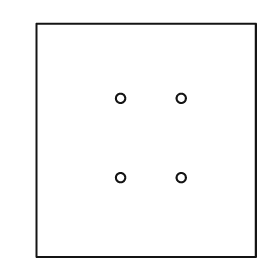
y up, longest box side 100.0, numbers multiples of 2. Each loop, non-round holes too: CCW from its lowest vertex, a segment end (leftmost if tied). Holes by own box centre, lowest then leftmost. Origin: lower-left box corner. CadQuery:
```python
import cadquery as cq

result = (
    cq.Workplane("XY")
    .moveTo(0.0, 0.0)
    .lineTo(94.0, 0.0)
    .lineTo(94.0, 100.0)
    .lineTo(0.0, 100.0)
    .close()
    .moveTo(36.0, 34.0)
    .circle(2.0)
    .moveTo(62.0, 34.0)
    .circle(2.0)
    .moveTo(36.0, 68.0)
    .circle(2.0)
    .moveTo(62.0, 68.0)
    .circle(2.0)
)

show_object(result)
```